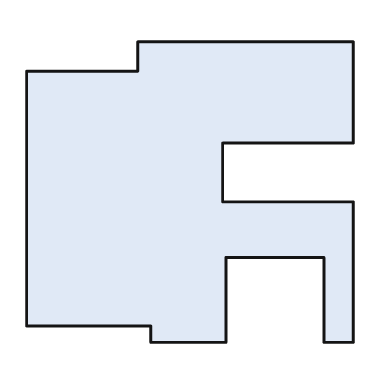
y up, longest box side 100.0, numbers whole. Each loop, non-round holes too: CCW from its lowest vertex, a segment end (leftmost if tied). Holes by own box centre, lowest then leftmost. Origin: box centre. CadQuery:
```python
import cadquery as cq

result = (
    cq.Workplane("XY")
    .moveTo(-12.0, -46.0)
    .lineTo(11.0, -46.0)
    .lineTo(11.0, -20.0)
    .lineTo(41.0, -20.0)
    .lineTo(41.0, -46.0)
    .lineTo(50.0, -46.0)
    .lineTo(50.0, -3.0)
    .lineTo(10.0, -3.0)
    .lineTo(10.0, 15.0)
    .lineTo(50.0, 15.0)
    .lineTo(50.0, 46.0)
    .lineTo(-16.0, 46.0)
    .lineTo(-16.0, 37.0)
    .lineTo(-50.0, 37.0)
    .lineTo(-50.0, -41.0)
    .lineTo(-12.0, -41.0)
    .close()
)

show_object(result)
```